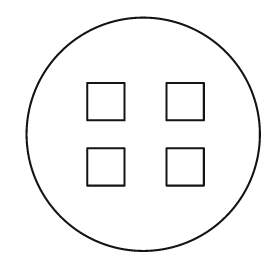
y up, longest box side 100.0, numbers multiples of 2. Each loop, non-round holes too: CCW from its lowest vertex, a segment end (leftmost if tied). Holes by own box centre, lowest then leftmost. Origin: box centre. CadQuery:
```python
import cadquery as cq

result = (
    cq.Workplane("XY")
    .moveTo(0.0, 0.0)
    .circle(50.0)
    .moveTo(-24.0, -22.0)
    .lineTo(-8.0, -22.0)
    .lineTo(-8.0, -6.0)
    .lineTo(-24.0, -6.0)
    .close()
    .moveTo(10.0, -22.0)
    .lineTo(26.0, -22.0)
    .lineTo(26.0, -6.0)
    .lineTo(10.0, -6.0)
    .close()
    .moveTo(-24.0, 6.0)
    .lineTo(-8.0, 6.0)
    .lineTo(-8.0, 22.0)
    .lineTo(-24.0, 22.0)
    .close()
    .moveTo(10.0, 6.0)
    .lineTo(26.0, 6.0)
    .lineTo(26.0, 22.0)
    .lineTo(10.0, 22.0)
    .close()
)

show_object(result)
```